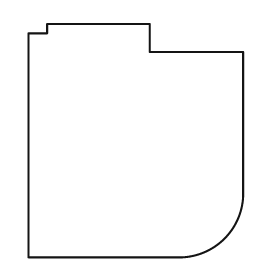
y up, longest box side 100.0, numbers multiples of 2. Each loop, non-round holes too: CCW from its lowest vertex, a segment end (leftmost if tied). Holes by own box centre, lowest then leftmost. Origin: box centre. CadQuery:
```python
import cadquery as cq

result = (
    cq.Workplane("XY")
    .moveTo(-46.0, -50.0)
    .lineTo(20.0, -50.0)
    .threePointArc((38.0, -42.0), (46.0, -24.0))
    .lineTo(46.0, 38.0)
    .lineTo(6.0, 38.0)
    .lineTo(6.0, 50.0)
    .lineTo(-38.0, 50.0)
    .lineTo(-38.0, 46.0)
    .lineTo(-46.0, 46.0)
    .close()
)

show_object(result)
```